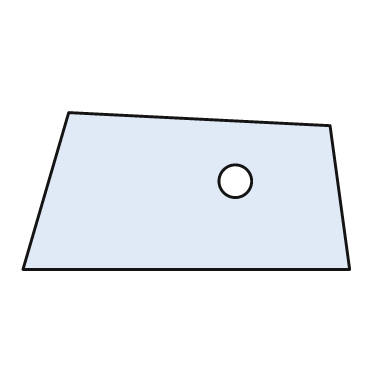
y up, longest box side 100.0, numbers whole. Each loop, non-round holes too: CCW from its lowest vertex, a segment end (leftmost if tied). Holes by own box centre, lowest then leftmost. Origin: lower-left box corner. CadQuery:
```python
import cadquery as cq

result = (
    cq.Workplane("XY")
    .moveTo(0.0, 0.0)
    .lineTo(100.0, 0.0)
    .lineTo(94.0, 44.0)
    .lineTo(14.0, 48.0)
    .close()
    .moveTo(65.0, 27.0)
    .circle(5.0)
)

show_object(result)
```